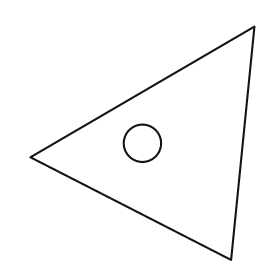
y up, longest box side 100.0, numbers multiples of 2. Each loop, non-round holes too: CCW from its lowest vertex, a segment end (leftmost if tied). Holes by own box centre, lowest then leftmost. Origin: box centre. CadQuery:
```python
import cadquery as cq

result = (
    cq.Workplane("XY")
    .moveTo(38.0, -50.0)
    .lineTo(48.0, 50.0)
    .lineTo(-48.0, -6.0)
    .close()
    .moveTo(0.0, 0.0)
    .circle(8.0)
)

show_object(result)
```